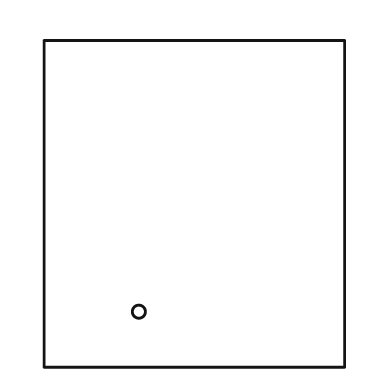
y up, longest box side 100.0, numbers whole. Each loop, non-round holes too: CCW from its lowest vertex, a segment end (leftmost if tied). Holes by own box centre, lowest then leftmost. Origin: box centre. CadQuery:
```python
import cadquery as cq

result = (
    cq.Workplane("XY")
    .moveTo(-46.0, -50.0)
    .lineTo(46.0, -50.0)
    .lineTo(46.0, 50.0)
    .lineTo(-46.0, 50.0)
    .close()
    .moveTo(-17.0, -33.0)
    .circle(2.0)
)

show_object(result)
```